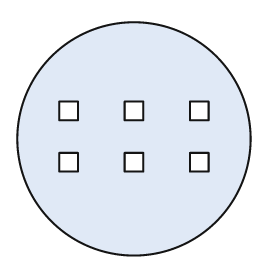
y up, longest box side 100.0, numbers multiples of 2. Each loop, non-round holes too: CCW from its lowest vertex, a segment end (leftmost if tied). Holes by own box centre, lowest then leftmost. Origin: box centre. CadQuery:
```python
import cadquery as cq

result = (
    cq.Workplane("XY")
    .moveTo(0.0, 0.0)
    .circle(50.0)
    .moveTo(-32.0, -14.0)
    .lineTo(-24.0, -14.0)
    .lineTo(-24.0, -6.0)
    .lineTo(-32.0, -6.0)
    .close()
    .moveTo(-4.0, -14.0)
    .lineTo(4.0, -14.0)
    .lineTo(4.0, -6.0)
    .lineTo(-4.0, -6.0)
    .close()
    .moveTo(24.0, -14.0)
    .lineTo(32.0, -14.0)
    .lineTo(32.0, -6.0)
    .lineTo(24.0, -6.0)
    .close()
    .moveTo(-32.0, 8.0)
    .lineTo(-24.0, 8.0)
    .lineTo(-24.0, 16.0)
    .lineTo(-32.0, 16.0)
    .close()
    .moveTo(-4.0, 8.0)
    .lineTo(4.0, 8.0)
    .lineTo(4.0, 16.0)
    .lineTo(-4.0, 16.0)
    .close()
    .moveTo(24.0, 8.0)
    .lineTo(32.0, 8.0)
    .lineTo(32.0, 16.0)
    .lineTo(24.0, 16.0)
    .close()
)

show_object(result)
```